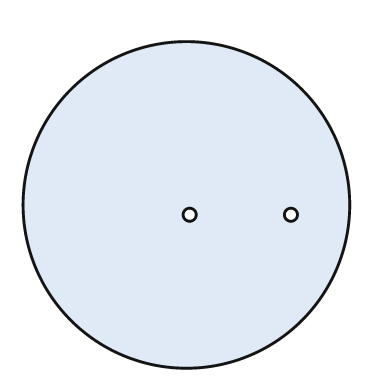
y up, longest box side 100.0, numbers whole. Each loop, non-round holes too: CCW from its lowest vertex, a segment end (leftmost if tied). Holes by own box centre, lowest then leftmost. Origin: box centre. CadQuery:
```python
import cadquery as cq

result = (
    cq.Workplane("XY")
    .moveTo(0.0, 0.0)
    .circle(50.0)
    .moveTo(1.0, -3.0)
    .circle(2.0)
    .moveTo(32.0, -3.0)
    .circle(2.0)
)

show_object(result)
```